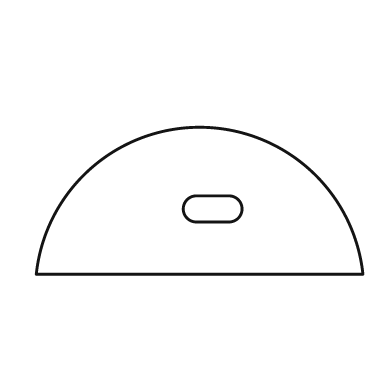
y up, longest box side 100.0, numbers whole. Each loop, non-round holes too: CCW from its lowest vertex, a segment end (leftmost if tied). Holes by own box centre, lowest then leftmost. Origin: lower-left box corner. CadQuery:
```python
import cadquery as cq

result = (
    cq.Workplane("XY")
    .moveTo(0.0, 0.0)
    .lineTo(100.0, 0.0)
    .threePointArc((50.0, 45.0), (0.0, 0.0))
    .close()
    .moveTo(49.0, 16.0)
    .lineTo(59.0, 16.0)
    .threePointArc((63.0, 20.0), (59.0, 24.0))
    .lineTo(49.0, 24.0)
    .threePointArc((45.0, 20.0), (49.0, 16.0))
    .close()
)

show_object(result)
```